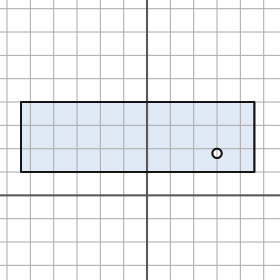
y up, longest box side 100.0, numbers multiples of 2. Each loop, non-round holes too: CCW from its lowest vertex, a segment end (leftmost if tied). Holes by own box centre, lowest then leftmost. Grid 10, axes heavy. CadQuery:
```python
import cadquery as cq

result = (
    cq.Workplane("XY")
    .moveTo(-54.0, 10.0)
    .lineTo(46.0, 10.0)
    .lineTo(46.0, 40.0)
    .lineTo(-54.0, 40.0)
    .close()
    .moveTo(30.0, 18.0)
    .circle(2.0)
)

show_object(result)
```